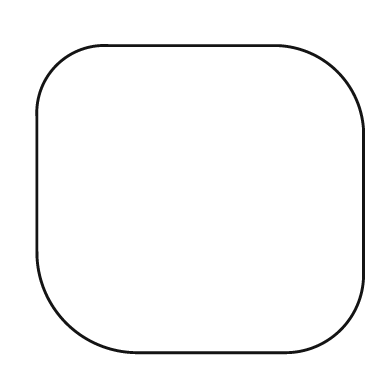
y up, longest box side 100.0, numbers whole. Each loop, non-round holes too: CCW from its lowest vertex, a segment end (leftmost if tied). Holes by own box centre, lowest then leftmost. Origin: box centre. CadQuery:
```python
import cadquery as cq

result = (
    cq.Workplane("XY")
    .moveTo(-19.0, -47.0)
    .lineTo(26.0, -47.0)
    .threePointArc((43.0, -40.0), (50.0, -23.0))
    .lineTo(50.0, 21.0)
    .threePointArc((42.0, 39.0), (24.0, 47.0))
    .lineTo(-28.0, 47.0)
    .threePointArc((-44.0, 41.0), (-50.0, 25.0))
    .lineTo(-50.0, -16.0)
    .threePointArc((-41.0, -38.0), (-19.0, -47.0))
    .close()
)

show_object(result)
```